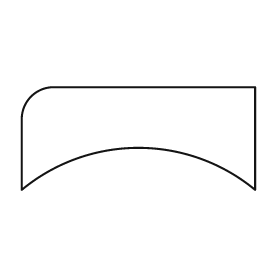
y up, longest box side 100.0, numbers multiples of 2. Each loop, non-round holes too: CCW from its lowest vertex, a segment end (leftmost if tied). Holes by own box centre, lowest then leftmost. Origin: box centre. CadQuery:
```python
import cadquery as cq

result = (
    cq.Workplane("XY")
    .moveTo(-50.0, -22.0)
    .threePointArc((0.0, -4.0), (50.0, -22.0))
    .lineTo(50.0, 22.0)
    .lineTo(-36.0, 22.0)
    .threePointArc((-46.0, 18.0), (-50.0, 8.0))
    .close()
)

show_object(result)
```